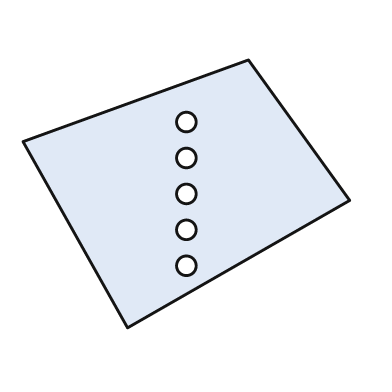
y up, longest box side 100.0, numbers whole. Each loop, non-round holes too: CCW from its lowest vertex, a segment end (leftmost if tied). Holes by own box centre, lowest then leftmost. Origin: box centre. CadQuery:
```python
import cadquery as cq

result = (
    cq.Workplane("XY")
    .moveTo(-18.0, -41.0)
    .lineTo(50.0, -2.0)
    .lineTo(19.0, 41.0)
    .lineTo(-50.0, 16.0)
    .close()
    .moveTo(0.0, -22.0)
    .circle(3.0)
    .moveTo(0.0, -11.0)
    .circle(3.0)
    .moveTo(0.0, 0.0)
    .circle(3.0)
    .moveTo(0.0, 11.0)
    .circle(3.0)
    .moveTo(0.0, 22.0)
    .circle(3.0)
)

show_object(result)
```